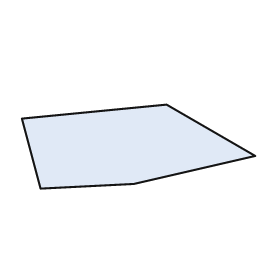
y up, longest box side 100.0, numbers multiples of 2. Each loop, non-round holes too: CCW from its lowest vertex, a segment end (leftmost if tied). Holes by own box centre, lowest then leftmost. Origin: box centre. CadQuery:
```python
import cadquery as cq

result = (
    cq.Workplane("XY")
    .moveTo(-42.0, -18.0)
    .lineTo(-2.0, -16.0)
    .lineTo(50.0, -4.0)
    .lineTo(12.0, 18.0)
    .lineTo(-50.0, 12.0)
    .close()
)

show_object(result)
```